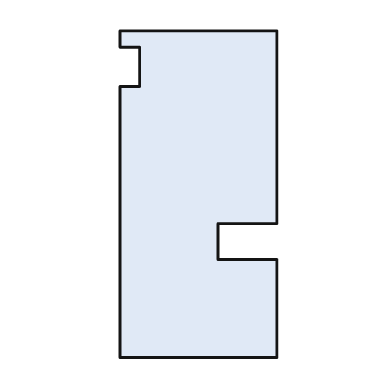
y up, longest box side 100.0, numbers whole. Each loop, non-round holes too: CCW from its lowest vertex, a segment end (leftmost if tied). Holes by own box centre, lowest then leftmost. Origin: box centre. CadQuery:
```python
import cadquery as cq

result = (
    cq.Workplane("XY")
    .moveTo(-24.0, -50.0)
    .lineTo(24.0, -50.0)
    .lineTo(24.0, -20.0)
    .lineTo(6.0, -20.0)
    .lineTo(6.0, -9.0)
    .lineTo(24.0, -9.0)
    .lineTo(24.0, 50.0)
    .lineTo(-24.0, 50.0)
    .lineTo(-24.0, 45.0)
    .lineTo(-18.0, 45.0)
    .lineTo(-18.0, 33.0)
    .lineTo(-24.0, 33.0)
    .close()
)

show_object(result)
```